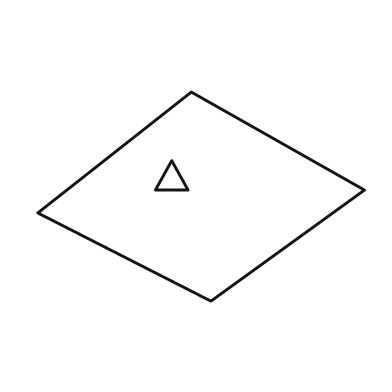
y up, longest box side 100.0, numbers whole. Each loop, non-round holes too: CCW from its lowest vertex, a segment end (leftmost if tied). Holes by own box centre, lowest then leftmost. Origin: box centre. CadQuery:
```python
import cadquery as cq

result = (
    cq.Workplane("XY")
    .moveTo(3.0, -32.0)
    .lineTo(50.0, 2.0)
    .lineTo(-3.0, 32.0)
    .lineTo(-50.0, -5.0)
    .close()
    .moveTo(-14.0, 2.0)
    .lineTo(-4.0, 2.0)
    .lineTo(-9.0, 11.0)
    .close()
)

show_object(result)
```